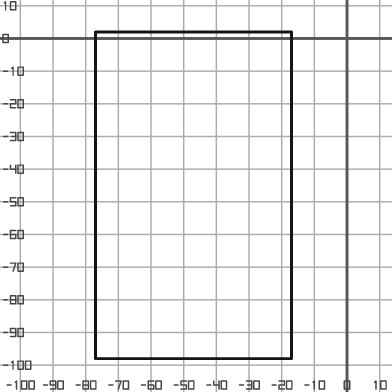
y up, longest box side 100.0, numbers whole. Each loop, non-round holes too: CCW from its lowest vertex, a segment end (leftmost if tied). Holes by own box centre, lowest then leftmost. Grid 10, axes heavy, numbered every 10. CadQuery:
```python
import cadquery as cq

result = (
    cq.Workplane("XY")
    .moveTo(-77.0, -98.0)
    .lineTo(-17.0, -98.0)
    .lineTo(-17.0, 2.0)
    .lineTo(-77.0, 2.0)
    .close()
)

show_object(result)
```